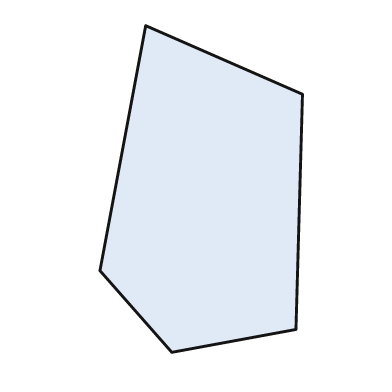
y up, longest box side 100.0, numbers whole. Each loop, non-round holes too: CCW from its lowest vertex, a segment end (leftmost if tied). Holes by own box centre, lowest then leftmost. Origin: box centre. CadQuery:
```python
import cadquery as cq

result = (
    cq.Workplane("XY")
    .moveTo(-9.0, -50.0)
    .lineTo(29.0, -43.0)
    .lineTo(31.0, 29.0)
    .lineTo(-17.0, 50.0)
    .lineTo(-31.0, -25.0)
    .close()
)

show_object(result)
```